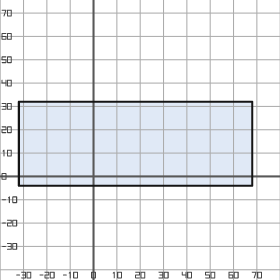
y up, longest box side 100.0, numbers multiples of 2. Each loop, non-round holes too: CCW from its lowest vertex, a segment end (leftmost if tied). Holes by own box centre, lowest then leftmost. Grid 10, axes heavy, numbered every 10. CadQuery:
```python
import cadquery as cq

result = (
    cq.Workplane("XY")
    .moveTo(-32.0, -4.0)
    .lineTo(68.0, -4.0)
    .lineTo(68.0, 32.0)
    .lineTo(-32.0, 32.0)
    .close()
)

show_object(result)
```